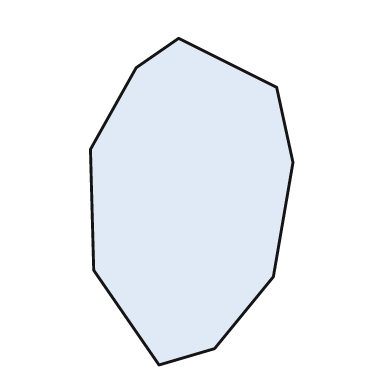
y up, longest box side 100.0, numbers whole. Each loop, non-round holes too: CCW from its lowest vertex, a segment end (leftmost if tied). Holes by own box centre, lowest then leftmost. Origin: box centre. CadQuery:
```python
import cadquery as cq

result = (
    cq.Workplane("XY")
    .moveTo(-10.0, -50.0)
    .lineTo(7.0, -45.0)
    .lineTo(25.0, -23.0)
    .lineTo(31.0, 12.0)
    .lineTo(26.0, 35.0)
    .lineTo(-4.0, 50.0)
    .lineTo(-17.0, 41.0)
    .lineTo(-31.0, 16.0)
    .lineTo(-30.0, -21.0)
    .close()
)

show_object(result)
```